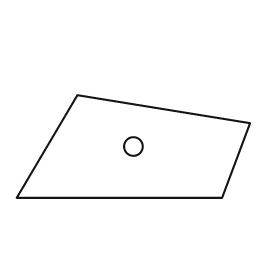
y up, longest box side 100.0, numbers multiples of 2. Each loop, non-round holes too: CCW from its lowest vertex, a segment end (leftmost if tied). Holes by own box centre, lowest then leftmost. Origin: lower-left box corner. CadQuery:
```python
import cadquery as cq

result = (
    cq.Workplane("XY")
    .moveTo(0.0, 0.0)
    .lineTo(88.0, 0.0)
    .lineTo(100.0, 32.0)
    .lineTo(26.0, 44.0)
    .close()
    .moveTo(50.0, 22.0)
    .circle(4.0)
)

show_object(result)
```